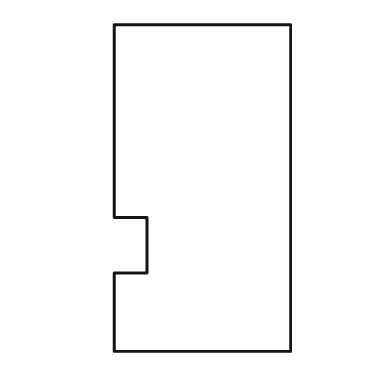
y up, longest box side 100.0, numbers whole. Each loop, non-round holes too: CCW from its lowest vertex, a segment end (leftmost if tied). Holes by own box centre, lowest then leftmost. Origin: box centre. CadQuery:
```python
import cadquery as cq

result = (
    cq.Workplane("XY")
    .moveTo(-27.0, -50.0)
    .lineTo(27.0, -50.0)
    .lineTo(27.0, 50.0)
    .lineTo(-27.0, 50.0)
    .lineTo(-27.0, -9.0)
    .lineTo(-17.0, -9.0)
    .lineTo(-17.0, -26.0)
    .lineTo(-27.0, -26.0)
    .close()
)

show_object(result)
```